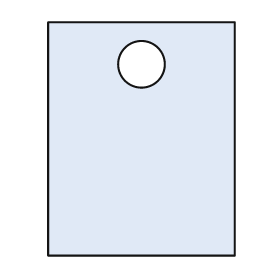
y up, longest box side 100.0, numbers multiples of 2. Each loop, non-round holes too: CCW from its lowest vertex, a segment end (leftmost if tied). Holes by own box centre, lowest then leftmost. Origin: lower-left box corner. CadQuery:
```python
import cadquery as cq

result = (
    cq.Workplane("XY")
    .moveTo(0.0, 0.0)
    .lineTo(80.0, 0.0)
    .lineTo(80.0, 100.0)
    .lineTo(0.0, 100.0)
    .close()
    .moveTo(40.0, 82.0)
    .circle(10.0)
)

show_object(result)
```